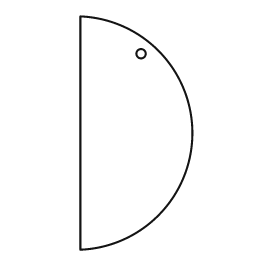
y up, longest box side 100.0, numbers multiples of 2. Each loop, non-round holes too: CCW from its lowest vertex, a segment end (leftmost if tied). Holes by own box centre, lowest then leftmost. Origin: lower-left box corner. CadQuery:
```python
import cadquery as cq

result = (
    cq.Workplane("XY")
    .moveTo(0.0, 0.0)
    .threePointArc((48.0, 50.0), (0.0, 100.0))
    .close()
    .moveTo(26.0, 84.0)
    .circle(2.0)
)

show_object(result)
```